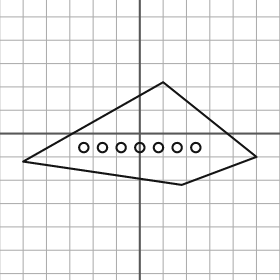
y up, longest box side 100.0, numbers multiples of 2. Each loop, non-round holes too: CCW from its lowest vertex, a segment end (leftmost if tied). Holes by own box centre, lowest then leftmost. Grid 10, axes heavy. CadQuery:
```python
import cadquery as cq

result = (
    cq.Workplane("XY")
    .moveTo(18.0, -22.0)
    .lineTo(50.0, -10.0)
    .lineTo(10.0, 22.0)
    .lineTo(-50.0, -12.0)
    .close()
    .moveTo(-24.0, -6.0)
    .circle(2.0)
    .moveTo(-16.0, -6.0)
    .circle(2.0)
    .moveTo(-8.0, -6.0)
    .circle(2.0)
    .moveTo(0.0, -6.0)
    .circle(2.0)
    .moveTo(8.0, -6.0)
    .circle(2.0)
    .moveTo(16.0, -6.0)
    .circle(2.0)
    .moveTo(24.0, -6.0)
    .circle(2.0)
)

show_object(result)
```